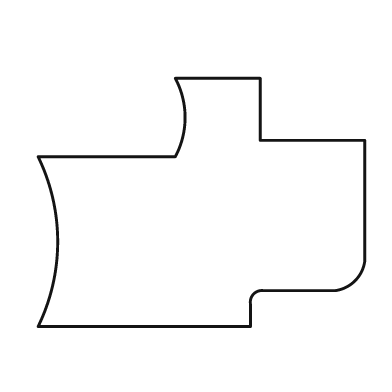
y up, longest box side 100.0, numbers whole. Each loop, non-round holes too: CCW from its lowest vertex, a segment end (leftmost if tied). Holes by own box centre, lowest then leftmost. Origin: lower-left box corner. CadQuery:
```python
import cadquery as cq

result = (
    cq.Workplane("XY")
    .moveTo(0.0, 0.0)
    .lineTo(65.0, 0.0)
    .lineTo(65.0, 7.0)
    .threePointArc((66.0, 10.0), (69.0, 11.0))
    .lineTo(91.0, 11.0)
    .threePointArc((97.0, 14.0), (100.0, 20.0))
    .lineTo(100.0, 57.0)
    .lineTo(68.0, 57.0)
    .lineTo(68.0, 76.0)
    .lineTo(42.0, 76.0)
    .threePointArc((45.0, 64.0), (42.0, 52.0))
    .lineTo(0.0, 52.0)
    .threePointArc((6.0, 26.0), (0.0, 0.0))
    .close()
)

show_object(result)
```